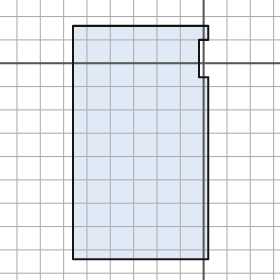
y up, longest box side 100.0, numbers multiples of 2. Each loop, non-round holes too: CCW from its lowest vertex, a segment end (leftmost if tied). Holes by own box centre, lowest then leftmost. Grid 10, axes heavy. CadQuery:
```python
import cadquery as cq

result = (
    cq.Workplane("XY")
    .moveTo(-56.0, -84.0)
    .lineTo(2.0, -84.0)
    .lineTo(2.0, -6.0)
    .lineTo(-2.0, -6.0)
    .lineTo(-2.0, 10.0)
    .lineTo(2.0, 10.0)
    .lineTo(2.0, 16.0)
    .lineTo(-56.0, 16.0)
    .close()
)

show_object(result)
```